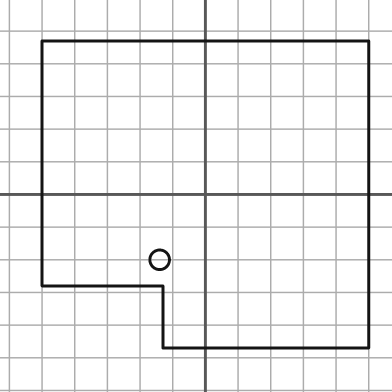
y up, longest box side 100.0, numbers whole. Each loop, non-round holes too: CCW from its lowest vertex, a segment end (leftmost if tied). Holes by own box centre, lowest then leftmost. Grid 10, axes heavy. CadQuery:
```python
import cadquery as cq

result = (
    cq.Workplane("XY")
    .moveTo(-13.0, -47.0)
    .lineTo(50.0, -47.0)
    .lineTo(50.0, 47.0)
    .lineTo(-50.0, 47.0)
    .lineTo(-50.0, -28.0)
    .lineTo(-13.0, -28.0)
    .close()
    .moveTo(-14.0, -20.0)
    .circle(3.0)
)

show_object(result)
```